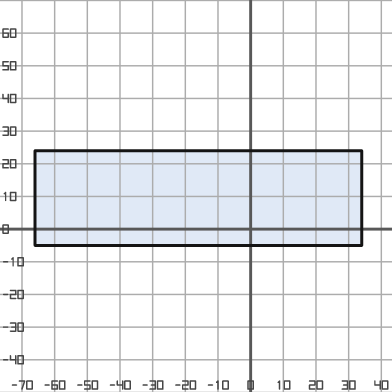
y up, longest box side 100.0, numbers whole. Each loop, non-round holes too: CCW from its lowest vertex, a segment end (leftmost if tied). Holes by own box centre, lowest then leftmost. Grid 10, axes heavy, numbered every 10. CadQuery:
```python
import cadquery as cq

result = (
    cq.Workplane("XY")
    .moveTo(-66.0, -5.0)
    .lineTo(34.0, -5.0)
    .lineTo(34.0, 24.0)
    .lineTo(-66.0, 24.0)
    .close()
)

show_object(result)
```